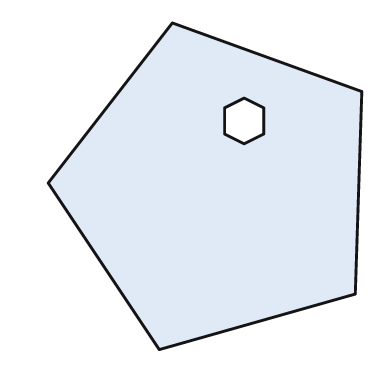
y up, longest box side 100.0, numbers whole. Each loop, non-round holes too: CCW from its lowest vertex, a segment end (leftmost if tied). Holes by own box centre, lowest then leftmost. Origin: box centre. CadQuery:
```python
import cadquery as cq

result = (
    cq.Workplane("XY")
    .moveTo(-14.0, -50.0)
    .lineTo(46.0, -33.0)
    .lineTo(48.0, 29.0)
    .lineTo(-10.0, 50.0)
    .lineTo(-48.0, 1.0)
    .close()
    .moveTo(12.0, 13.0)
    .lineTo(18.0, 16.0)
    .lineTo(18.0, 24.0)
    .lineTo(12.0, 27.0)
    .lineTo(6.0, 24.0)
    .lineTo(6.0, 16.0)
    .close()
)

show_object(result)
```